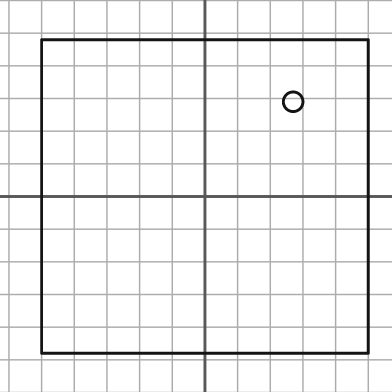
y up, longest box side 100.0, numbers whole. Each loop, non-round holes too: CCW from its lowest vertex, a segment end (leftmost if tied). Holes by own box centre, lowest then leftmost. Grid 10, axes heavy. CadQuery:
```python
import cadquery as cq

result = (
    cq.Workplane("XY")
    .moveTo(-50.0, -48.0)
    .lineTo(50.0, -48.0)
    .lineTo(50.0, 48.0)
    .lineTo(-50.0, 48.0)
    .close()
    .moveTo(27.0, 29.0)
    .circle(3.0)
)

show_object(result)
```